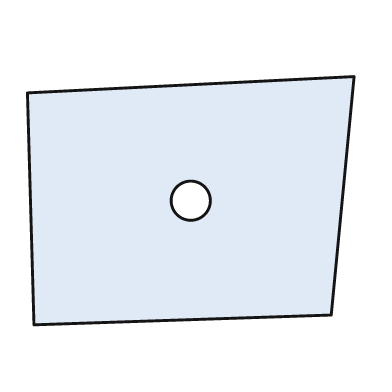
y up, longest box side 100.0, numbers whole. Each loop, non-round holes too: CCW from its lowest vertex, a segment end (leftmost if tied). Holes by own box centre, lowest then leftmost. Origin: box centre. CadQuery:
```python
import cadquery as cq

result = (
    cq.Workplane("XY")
    .moveTo(-48.0, -38.0)
    .lineTo(43.0, -35.0)
    .lineTo(50.0, 38.0)
    .lineTo(-50.0, 33.0)
    .close()
    .moveTo(0.0, 0.0)
    .circle(6.0)
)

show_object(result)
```